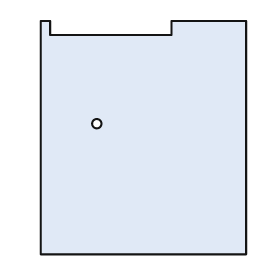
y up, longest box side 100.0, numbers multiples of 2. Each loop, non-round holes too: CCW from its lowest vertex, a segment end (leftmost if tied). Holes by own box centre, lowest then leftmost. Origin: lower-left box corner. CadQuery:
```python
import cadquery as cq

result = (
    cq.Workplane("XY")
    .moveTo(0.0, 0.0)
    .lineTo(88.0, 0.0)
    .lineTo(88.0, 100.0)
    .lineTo(56.0, 100.0)
    .lineTo(56.0, 94.0)
    .lineTo(4.0, 94.0)
    .lineTo(4.0, 100.0)
    .lineTo(0.0, 100.0)
    .close()
    .moveTo(24.0, 56.0)
    .circle(2.0)
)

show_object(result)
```